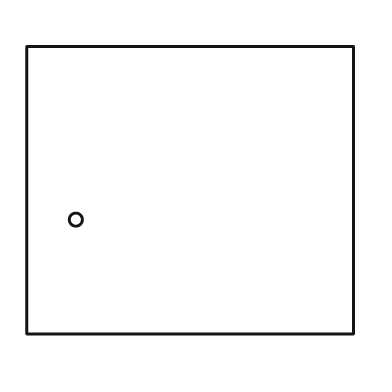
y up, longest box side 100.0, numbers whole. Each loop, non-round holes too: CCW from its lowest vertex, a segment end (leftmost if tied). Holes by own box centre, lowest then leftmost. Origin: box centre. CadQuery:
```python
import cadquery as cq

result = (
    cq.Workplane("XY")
    .moveTo(-50.0, -44.0)
    .lineTo(50.0, -44.0)
    .lineTo(50.0, 44.0)
    .lineTo(-50.0, 44.0)
    .close()
    .moveTo(-35.0, -9.0)
    .circle(2.0)
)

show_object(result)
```